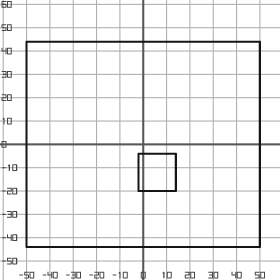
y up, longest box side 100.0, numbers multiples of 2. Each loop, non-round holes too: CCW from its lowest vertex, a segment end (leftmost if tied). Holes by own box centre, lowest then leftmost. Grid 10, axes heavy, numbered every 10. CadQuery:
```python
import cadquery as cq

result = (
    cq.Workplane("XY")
    .moveTo(-50.0, -44.0)
    .lineTo(50.0, -44.0)
    .lineTo(50.0, 44.0)
    .lineTo(-50.0, 44.0)
    .close()
    .moveTo(-2.0, -20.0)
    .lineTo(14.0, -20.0)
    .lineTo(14.0, -4.0)
    .lineTo(-2.0, -4.0)
    .close()
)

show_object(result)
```